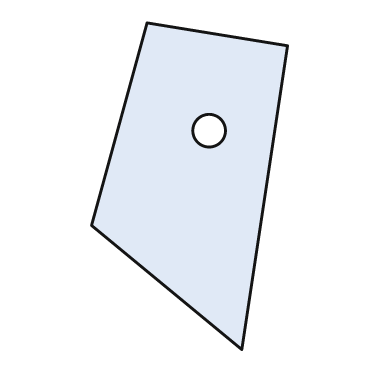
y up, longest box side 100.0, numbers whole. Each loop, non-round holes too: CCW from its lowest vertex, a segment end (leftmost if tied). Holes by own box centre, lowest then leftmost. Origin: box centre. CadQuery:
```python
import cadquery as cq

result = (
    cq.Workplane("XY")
    .moveTo(16.0, -50.0)
    .lineTo(30.0, 43.0)
    .lineTo(-13.0, 50.0)
    .lineTo(-30.0, -12.0)
    .close()
    .moveTo(6.0, 17.0)
    .circle(5.0)
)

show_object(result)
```